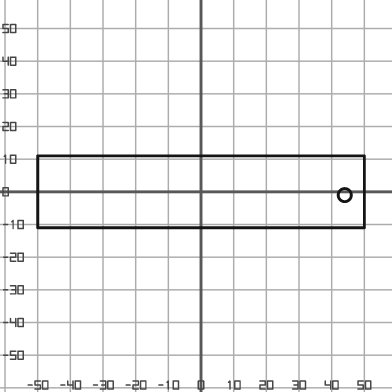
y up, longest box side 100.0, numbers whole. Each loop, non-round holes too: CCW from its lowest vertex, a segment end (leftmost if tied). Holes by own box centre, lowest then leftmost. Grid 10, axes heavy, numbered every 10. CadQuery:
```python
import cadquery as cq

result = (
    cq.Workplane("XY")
    .moveTo(-50.0, -11.0)
    .lineTo(50.0, -11.0)
    .lineTo(50.0, 11.0)
    .lineTo(-50.0, 11.0)
    .close()
    .moveTo(44.0, -1.0)
    .circle(2.0)
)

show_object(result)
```